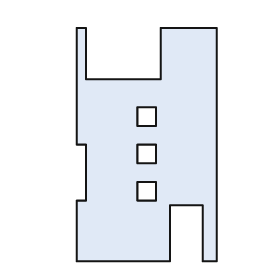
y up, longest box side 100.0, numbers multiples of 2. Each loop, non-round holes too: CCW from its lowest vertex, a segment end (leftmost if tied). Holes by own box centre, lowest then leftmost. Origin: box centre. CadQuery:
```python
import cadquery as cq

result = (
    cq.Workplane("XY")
    .moveTo(-30.0, -50.0)
    .lineTo(10.0, -50.0)
    .lineTo(10.0, -26.0)
    .lineTo(24.0, -26.0)
    .lineTo(24.0, -50.0)
    .lineTo(30.0, -50.0)
    .lineTo(30.0, 50.0)
    .lineTo(6.0, 50.0)
    .lineTo(6.0, 28.0)
    .lineTo(-26.0, 28.0)
    .lineTo(-26.0, 50.0)
    .lineTo(-30.0, 50.0)
    .lineTo(-30.0, 0.0)
    .lineTo(-26.0, 0.0)
    .lineTo(-26.0, -24.0)
    .lineTo(-30.0, -24.0)
    .close()
    .moveTo(-4.0, -24.0)
    .lineTo(4.0, -24.0)
    .lineTo(4.0, -16.0)
    .lineTo(-4.0, -16.0)
    .close()
    .moveTo(-4.0, -8.0)
    .lineTo(4.0, -8.0)
    .lineTo(4.0, 0.0)
    .lineTo(-4.0, 0.0)
    .close()
    .moveTo(-4.0, 8.0)
    .lineTo(4.0, 8.0)
    .lineTo(4.0, 16.0)
    .lineTo(-4.0, 16.0)
    .close()
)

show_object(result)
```